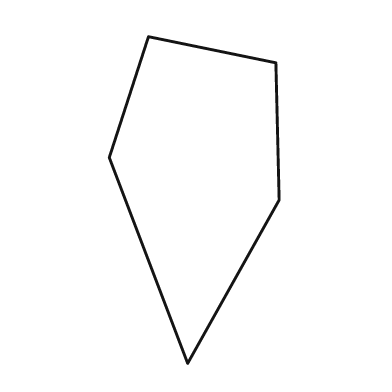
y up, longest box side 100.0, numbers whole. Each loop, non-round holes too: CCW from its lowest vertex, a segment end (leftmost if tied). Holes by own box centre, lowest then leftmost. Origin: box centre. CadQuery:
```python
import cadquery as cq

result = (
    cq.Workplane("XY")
    .moveTo(-2.0, -50.0)
    .lineTo(26.0, 0.0)
    .lineTo(25.0, 42.0)
    .lineTo(-14.0, 50.0)
    .lineTo(-26.0, 13.0)
    .close()
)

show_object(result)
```